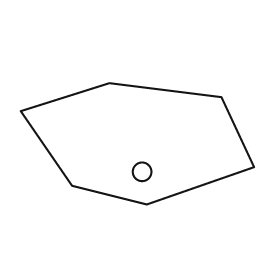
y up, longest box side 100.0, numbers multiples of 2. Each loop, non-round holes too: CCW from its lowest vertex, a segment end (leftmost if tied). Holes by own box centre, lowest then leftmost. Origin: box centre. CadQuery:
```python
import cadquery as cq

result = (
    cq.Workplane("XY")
    .moveTo(4.0, -26.0)
    .lineTo(50.0, -10.0)
    .lineTo(36.0, 20.0)
    .lineTo(-12.0, 26.0)
    .lineTo(-50.0, 14.0)
    .lineTo(-28.0, -18.0)
    .close()
    .moveTo(2.0, -12.0)
    .circle(4.0)
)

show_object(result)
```